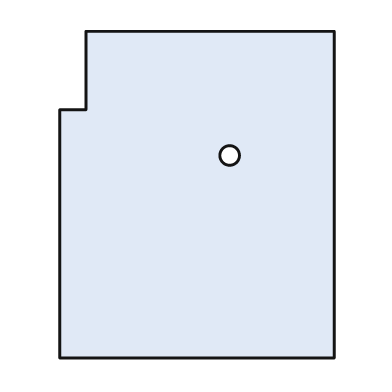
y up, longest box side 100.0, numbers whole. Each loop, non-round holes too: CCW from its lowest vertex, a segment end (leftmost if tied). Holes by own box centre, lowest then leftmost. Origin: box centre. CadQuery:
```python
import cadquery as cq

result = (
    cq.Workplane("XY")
    .moveTo(-42.0, -50.0)
    .lineTo(42.0, -50.0)
    .lineTo(42.0, 50.0)
    .lineTo(-34.0, 50.0)
    .lineTo(-34.0, 26.0)
    .lineTo(-42.0, 26.0)
    .close()
    .moveTo(10.0, 12.0)
    .circle(3.0)
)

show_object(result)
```